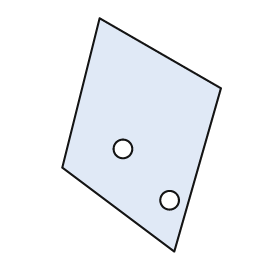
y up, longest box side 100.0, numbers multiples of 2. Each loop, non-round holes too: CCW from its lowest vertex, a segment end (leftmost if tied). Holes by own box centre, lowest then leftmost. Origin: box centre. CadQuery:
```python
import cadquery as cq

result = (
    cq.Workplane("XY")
    .moveTo(14.0, -50.0)
    .lineTo(34.0, 20.0)
    .lineTo(-18.0, 50.0)
    .lineTo(-34.0, -14.0)
    .close()
    .moveTo(12.0, -28.0)
    .circle(4.0)
    .moveTo(-8.0, -6.0)
    .circle(4.0)
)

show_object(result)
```